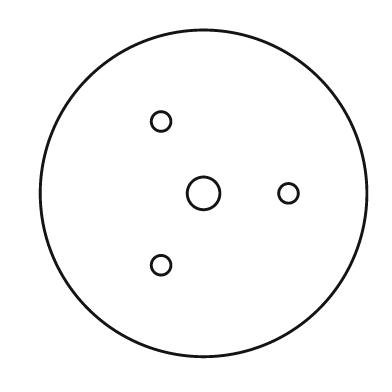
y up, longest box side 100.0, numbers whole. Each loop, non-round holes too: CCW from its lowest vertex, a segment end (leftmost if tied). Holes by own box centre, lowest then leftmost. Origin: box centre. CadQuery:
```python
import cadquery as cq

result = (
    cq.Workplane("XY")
    .moveTo(0.0, 0.0)
    .circle(50.0)
    .moveTo(-13.0, -22.0)
    .circle(3.0)
    .moveTo(0.0, 0.0)
    .circle(5.0)
    .moveTo(26.0, 0.0)
    .circle(3.0)
    .moveTo(-13.0, 22.0)
    .circle(3.0)
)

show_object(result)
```